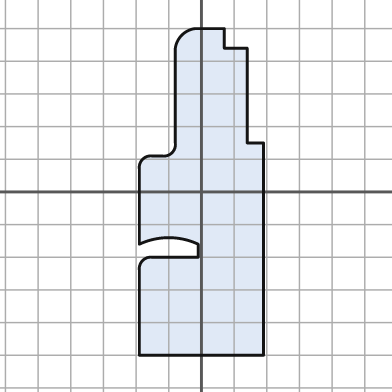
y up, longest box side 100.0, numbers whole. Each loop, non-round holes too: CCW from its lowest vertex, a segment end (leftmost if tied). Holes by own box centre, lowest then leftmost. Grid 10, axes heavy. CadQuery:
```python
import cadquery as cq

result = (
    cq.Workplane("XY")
    .moveTo(-19.0, -50.0)
    .lineTo(19.0, -50.0)
    .lineTo(19.0, 15.0)
    .lineTo(14.0, 15.0)
    .lineTo(14.0, 44.0)
    .lineTo(7.0, 44.0)
    .lineTo(7.0, 50.0)
    .lineTo(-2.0, 50.0)
    .threePointArc((-6.0, 48.0), (-8.0, 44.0))
    .lineTo(-8.0, 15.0)
    .threePointArc((-9.0, 12.0), (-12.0, 11.0))
    .lineTo(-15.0, 11.0)
    .threePointArc((-18.0, 10.0), (-19.0, 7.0))
    .lineTo(-19.0, -16.0)
    .threePointArc((-10.0, -14.0), (-1.0, -16.0))
    .lineTo(-1.0, -20.0)
    .lineTo(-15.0, -20.0)
    .threePointArc((-18.0, -21.0), (-19.0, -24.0))
    .close()
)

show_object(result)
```